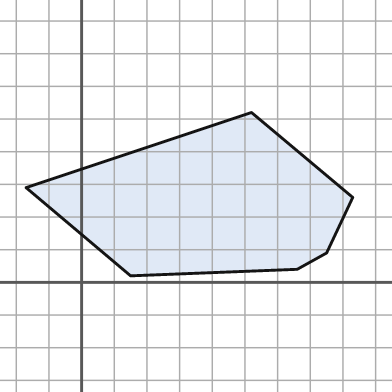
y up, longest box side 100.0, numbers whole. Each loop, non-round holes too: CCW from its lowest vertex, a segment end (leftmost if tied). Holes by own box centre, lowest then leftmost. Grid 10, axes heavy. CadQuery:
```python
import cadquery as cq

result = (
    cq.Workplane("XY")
    .moveTo(15.0, 2.0)
    .lineTo(66.0, 4.0)
    .lineTo(75.0, 9.0)
    .lineTo(83.0, 26.0)
    .lineTo(52.0, 52.0)
    .lineTo(-17.0, 29.0)
    .close()
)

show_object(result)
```